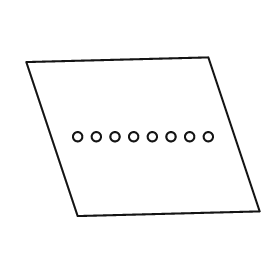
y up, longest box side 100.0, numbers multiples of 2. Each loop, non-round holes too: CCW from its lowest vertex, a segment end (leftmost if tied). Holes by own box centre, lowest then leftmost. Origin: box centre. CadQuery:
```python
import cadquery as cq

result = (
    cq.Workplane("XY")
    .moveTo(-28.0, -34.0)
    .lineTo(50.0, -32.0)
    .lineTo(28.0, 34.0)
    .lineTo(-50.0, 32.0)
    .close()
    .moveTo(-28.0, 0.0)
    .circle(2.0)
    .moveTo(-20.0, 0.0)
    .circle(2.0)
    .moveTo(-12.0, 0.0)
    .circle(2.0)
    .moveTo(-4.0, 0.0)
    .circle(2.0)
    .moveTo(4.0, 0.0)
    .circle(2.0)
    .moveTo(12.0, 0.0)
    .circle(2.0)
    .moveTo(20.0, 0.0)
    .circle(2.0)
    .moveTo(28.0, 0.0)
    .circle(2.0)
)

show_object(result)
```